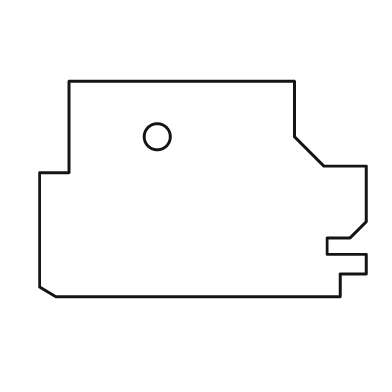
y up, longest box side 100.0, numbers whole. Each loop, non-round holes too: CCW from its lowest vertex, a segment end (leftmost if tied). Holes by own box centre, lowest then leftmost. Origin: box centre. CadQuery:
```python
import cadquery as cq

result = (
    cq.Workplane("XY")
    .moveTo(-45.0, -33.0)
    .lineTo(42.0, -33.0)
    .lineTo(42.0, -26.0)
    .lineTo(50.0, -26.0)
    .lineTo(50.0, -20.0)
    .lineTo(38.0, -20.0)
    .lineTo(38.0, -15.0)
    .lineTo(45.0, -15.0)
    .lineTo(50.0, -10.0)
    .lineTo(50.0, 7.0)
    .lineTo(37.0, 7.0)
    .lineTo(28.0, 16.0)
    .lineTo(28.0, 33.0)
    .lineTo(-41.0, 33.0)
    .lineTo(-41.0, 5.0)
    .lineTo(-50.0, 5.0)
    .lineTo(-50.0, -30.0)
    .close()
    .moveTo(-14.0, 16.0)
    .circle(4.0)
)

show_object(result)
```